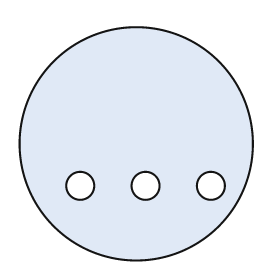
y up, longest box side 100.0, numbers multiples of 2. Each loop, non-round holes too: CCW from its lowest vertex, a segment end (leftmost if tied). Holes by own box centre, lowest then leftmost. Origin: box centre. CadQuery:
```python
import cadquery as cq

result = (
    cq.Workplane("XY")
    .moveTo(0.0, 0.0)
    .circle(50.0)
    .moveTo(-24.0, -18.0)
    .circle(6.0)
    .moveTo(4.0, -18.0)
    .circle(6.0)
    .moveTo(32.0, -18.0)
    .circle(6.0)
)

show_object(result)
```